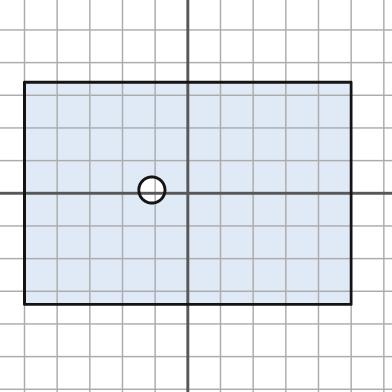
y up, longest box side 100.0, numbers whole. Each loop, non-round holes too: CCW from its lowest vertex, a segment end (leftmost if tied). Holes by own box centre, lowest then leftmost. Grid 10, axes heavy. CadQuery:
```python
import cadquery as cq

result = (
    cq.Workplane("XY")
    .moveTo(-50.0, -34.0)
    .lineTo(50.0, -34.0)
    .lineTo(50.0, 34.0)
    .lineTo(-50.0, 34.0)
    .close()
    .moveTo(-11.0, 1.0)
    .circle(4.0)
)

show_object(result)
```